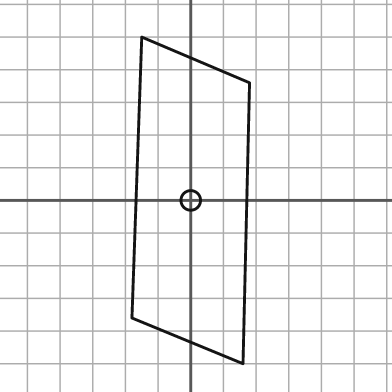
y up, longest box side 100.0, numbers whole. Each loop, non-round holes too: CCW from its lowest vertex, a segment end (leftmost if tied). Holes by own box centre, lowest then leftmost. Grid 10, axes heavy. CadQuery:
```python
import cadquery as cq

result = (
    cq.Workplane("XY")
    .moveTo(16.0, -50.0)
    .lineTo(18.0, 36.0)
    .lineTo(-15.0, 50.0)
    .lineTo(-18.0, -36.0)
    .close()
    .moveTo(0.0, 0.0)
    .circle(3.0)
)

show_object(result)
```